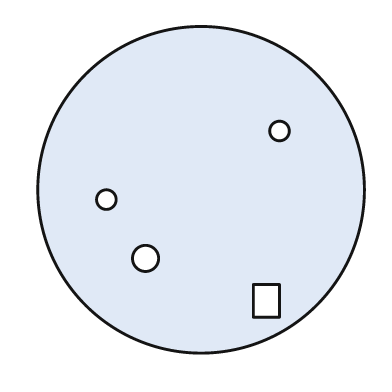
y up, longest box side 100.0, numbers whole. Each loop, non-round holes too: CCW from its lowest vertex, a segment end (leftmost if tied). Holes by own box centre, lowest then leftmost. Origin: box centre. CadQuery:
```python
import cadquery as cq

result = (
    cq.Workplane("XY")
    .moveTo(0.0, 0.0)
    .circle(50.0)
    .moveTo(16.0, -39.0)
    .lineTo(24.0, -39.0)
    .lineTo(24.0, -29.0)
    .lineTo(16.0, -29.0)
    .close()
    .moveTo(-17.0, -21.0)
    .circle(4.0)
    .moveTo(-29.0, -3.0)
    .circle(3.0)
    .moveTo(24.0, 18.0)
    .circle(3.0)
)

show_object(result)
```